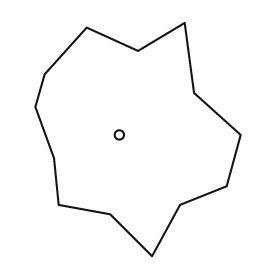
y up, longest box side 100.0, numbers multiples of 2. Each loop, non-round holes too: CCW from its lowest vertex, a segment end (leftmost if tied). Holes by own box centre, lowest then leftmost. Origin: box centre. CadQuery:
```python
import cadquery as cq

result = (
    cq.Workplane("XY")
    .moveTo(6.0, -50.0)
    .lineTo(18.0, -28.0)
    .lineTo(38.0, -20.0)
    .lineTo(44.0, 2.0)
    .lineTo(24.0, 20.0)
    .lineTo(20.0, 50.0)
    .lineTo(0.0, 38.0)
    .lineTo(-22.0, 48.0)
    .lineTo(-40.0, 28.0)
    .lineTo(-44.0, 14.0)
    .lineTo(-36.0, -8.0)
    .lineTo(-34.0, -28.0)
    .lineTo(-12.0, -32.0)
    .close()
    .moveTo(-8.0, 2.0)
    .circle(2.0)
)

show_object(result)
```